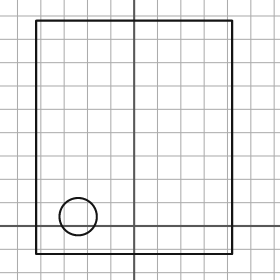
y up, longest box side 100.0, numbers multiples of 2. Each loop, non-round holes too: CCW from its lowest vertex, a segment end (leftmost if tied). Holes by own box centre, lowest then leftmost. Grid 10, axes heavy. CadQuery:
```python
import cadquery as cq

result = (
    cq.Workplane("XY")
    .moveTo(-42.0, -12.0)
    .lineTo(42.0, -12.0)
    .lineTo(42.0, 88.0)
    .lineTo(-42.0, 88.0)
    .close()
    .moveTo(-24.0, 4.0)
    .circle(8.0)
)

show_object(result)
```